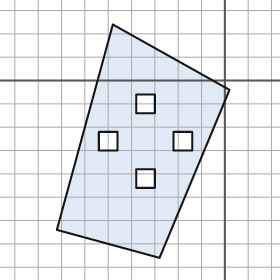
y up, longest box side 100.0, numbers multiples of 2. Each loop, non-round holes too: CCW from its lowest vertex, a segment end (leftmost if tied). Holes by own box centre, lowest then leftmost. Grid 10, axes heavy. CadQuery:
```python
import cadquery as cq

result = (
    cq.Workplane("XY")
    .moveTo(-28.0, -76.0)
    .lineTo(2.0, -4.0)
    .lineTo(-48.0, 24.0)
    .lineTo(-72.0, -64.0)
    .close()
    .moveTo(-38.0, -46.0)
    .lineTo(-30.0, -46.0)
    .lineTo(-30.0, -38.0)
    .lineTo(-38.0, -38.0)
    .close()
    .moveTo(-54.0, -30.0)
    .lineTo(-46.0, -30.0)
    .lineTo(-46.0, -22.0)
    .lineTo(-54.0, -22.0)
    .close()
    .moveTo(-22.0, -30.0)
    .lineTo(-14.0, -30.0)
    .lineTo(-14.0, -22.0)
    .lineTo(-22.0, -22.0)
    .close()
    .moveTo(-38.0, -14.0)
    .lineTo(-30.0, -14.0)
    .lineTo(-30.0, -6.0)
    .lineTo(-38.0, -6.0)
    .close()
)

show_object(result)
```